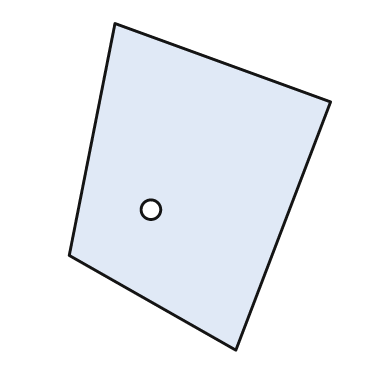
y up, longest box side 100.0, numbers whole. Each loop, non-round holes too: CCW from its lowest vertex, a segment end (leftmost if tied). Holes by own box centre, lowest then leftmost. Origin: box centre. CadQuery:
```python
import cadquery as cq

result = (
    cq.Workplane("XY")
    .moveTo(11.0, -50.0)
    .lineTo(40.0, 26.0)
    .lineTo(-26.0, 50.0)
    .lineTo(-40.0, -21.0)
    .close()
    .moveTo(-15.0, -7.0)
    .circle(3.0)
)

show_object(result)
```